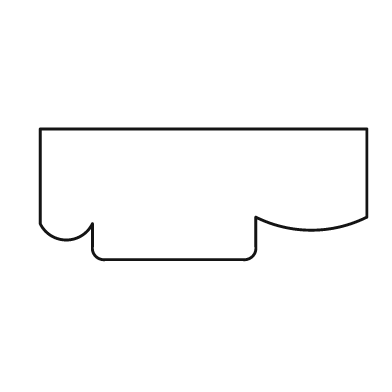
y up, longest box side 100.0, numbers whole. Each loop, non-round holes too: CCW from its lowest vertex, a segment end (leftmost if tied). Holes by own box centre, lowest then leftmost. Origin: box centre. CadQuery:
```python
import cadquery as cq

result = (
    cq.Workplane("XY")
    .moveTo(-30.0, -20.0)
    .lineTo(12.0, -20.0)
    .threePointArc((15.0, -19.0), (16.0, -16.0))
    .lineTo(16.0, -7.0)
    .threePointArc((33.0, -11.0), (50.0, -7.0))
    .lineTo(50.0, 20.0)
    .lineTo(-50.0, 20.0)
    .lineTo(-50.0, -9.0)
    .threePointArc((-42.0, -14.0), (-34.0, -9.0))
    .lineTo(-34.0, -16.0)
    .threePointArc((-33.0, -19.0), (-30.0, -20.0))
    .close()
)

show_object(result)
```